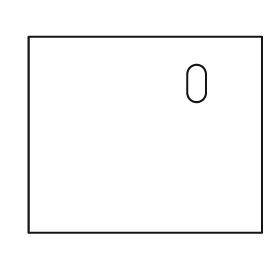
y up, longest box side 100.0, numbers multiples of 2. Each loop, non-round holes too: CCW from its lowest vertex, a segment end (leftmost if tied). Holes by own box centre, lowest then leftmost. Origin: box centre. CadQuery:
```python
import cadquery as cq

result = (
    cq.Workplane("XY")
    .moveTo(-50.0, -42.0)
    .lineTo(50.0, -42.0)
    .lineTo(50.0, 42.0)
    .lineTo(-50.0, 42.0)
    .close()
    .moveTo(18.0, 18.0)
    .threePointArc((22.0, 14.0), (26.0, 18.0))
    .lineTo(26.0, 26.0)
    .threePointArc((22.0, 30.0), (18.0, 26.0))
    .close()
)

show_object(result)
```